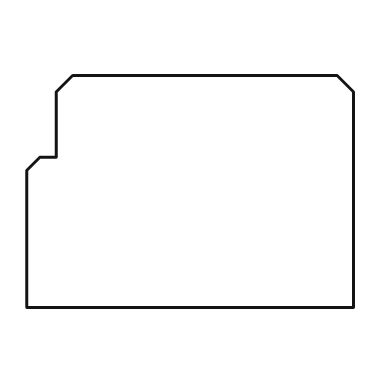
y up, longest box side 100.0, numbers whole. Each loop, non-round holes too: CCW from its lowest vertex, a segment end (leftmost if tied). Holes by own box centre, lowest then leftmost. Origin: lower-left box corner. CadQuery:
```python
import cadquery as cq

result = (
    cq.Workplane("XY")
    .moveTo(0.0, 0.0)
    .lineTo(100.0, 0.0)
    .lineTo(100.0, 66.0)
    .lineTo(95.0, 71.0)
    .lineTo(14.0, 71.0)
    .lineTo(9.0, 66.0)
    .lineTo(9.0, 46.0)
    .lineTo(4.0, 46.0)
    .lineTo(0.0, 42.0)
    .close()
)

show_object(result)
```